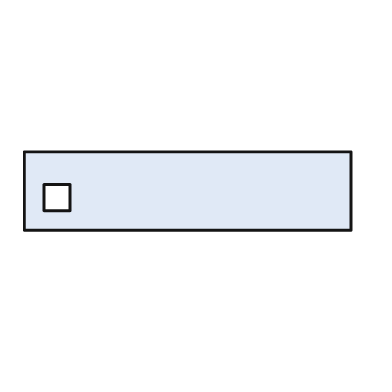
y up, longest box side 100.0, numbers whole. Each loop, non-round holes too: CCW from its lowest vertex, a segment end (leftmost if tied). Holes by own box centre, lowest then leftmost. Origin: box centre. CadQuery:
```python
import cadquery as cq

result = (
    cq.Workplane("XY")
    .moveTo(-50.0, -12.0)
    .lineTo(50.0, -12.0)
    .lineTo(50.0, 12.0)
    .lineTo(-50.0, 12.0)
    .close()
    .moveTo(-44.0, -6.0)
    .lineTo(-36.0, -6.0)
    .lineTo(-36.0, 2.0)
    .lineTo(-44.0, 2.0)
    .close()
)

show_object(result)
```